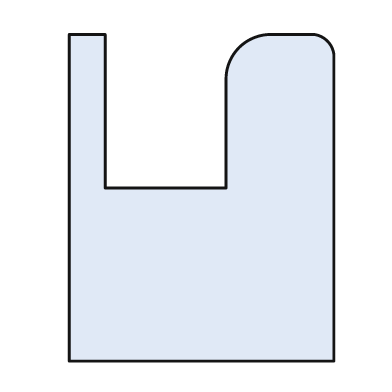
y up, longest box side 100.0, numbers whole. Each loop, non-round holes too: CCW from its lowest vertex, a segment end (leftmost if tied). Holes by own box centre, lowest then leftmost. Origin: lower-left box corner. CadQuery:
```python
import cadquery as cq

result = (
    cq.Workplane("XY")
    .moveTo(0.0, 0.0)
    .lineTo(81.0, 0.0)
    .lineTo(81.0, 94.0)
    .threePointArc((79.0, 98.0), (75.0, 100.0))
    .lineTo(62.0, 100.0)
    .threePointArc((52.0, 96.0), (48.0, 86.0))
    .lineTo(48.0, 53.0)
    .lineTo(11.0, 53.0)
    .lineTo(11.0, 100.0)
    .lineTo(0.0, 100.0)
    .close()
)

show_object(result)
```